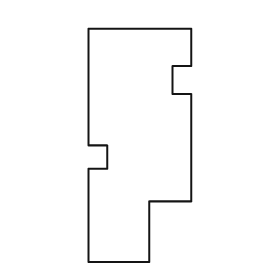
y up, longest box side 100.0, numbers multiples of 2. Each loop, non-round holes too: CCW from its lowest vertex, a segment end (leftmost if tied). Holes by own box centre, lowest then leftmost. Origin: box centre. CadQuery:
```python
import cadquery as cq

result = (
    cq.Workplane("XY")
    .moveTo(-22.0, -50.0)
    .lineTo(4.0, -50.0)
    .lineTo(4.0, -24.0)
    .lineTo(22.0, -24.0)
    .lineTo(22.0, 22.0)
    .lineTo(14.0, 22.0)
    .lineTo(14.0, 34.0)
    .lineTo(22.0, 34.0)
    .lineTo(22.0, 50.0)
    .lineTo(-22.0, 50.0)
    .lineTo(-22.0, 0.0)
    .lineTo(-14.0, 0.0)
    .lineTo(-14.0, -10.0)
    .lineTo(-22.0, -10.0)
    .close()
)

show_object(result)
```